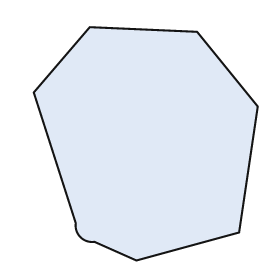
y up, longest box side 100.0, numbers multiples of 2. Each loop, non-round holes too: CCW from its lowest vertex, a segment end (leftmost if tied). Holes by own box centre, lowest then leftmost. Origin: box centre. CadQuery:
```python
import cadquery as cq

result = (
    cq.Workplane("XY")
    .moveTo(-4.0, -50.0)
    .lineTo(40.0, -38.0)
    .lineTo(48.0, 16.0)
    .lineTo(22.0, 48.0)
    .lineTo(-24.0, 50.0)
    .lineTo(-48.0, 22.0)
    .lineTo(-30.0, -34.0)
    .threePointArc((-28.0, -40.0), (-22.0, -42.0))
    .close()
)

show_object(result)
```